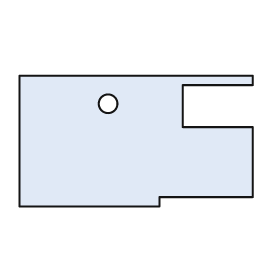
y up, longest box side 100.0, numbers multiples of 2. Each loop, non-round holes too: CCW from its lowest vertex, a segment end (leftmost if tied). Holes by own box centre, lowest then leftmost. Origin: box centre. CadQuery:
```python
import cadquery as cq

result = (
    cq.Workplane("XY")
    .moveTo(-50.0, -28.0)
    .lineTo(10.0, -28.0)
    .lineTo(10.0, -24.0)
    .lineTo(50.0, -24.0)
    .lineTo(50.0, 6.0)
    .lineTo(20.0, 6.0)
    .lineTo(20.0, 24.0)
    .lineTo(50.0, 24.0)
    .lineTo(50.0, 28.0)
    .lineTo(-50.0, 28.0)
    .close()
    .moveTo(-12.0, 16.0)
    .circle(4.0)
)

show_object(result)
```